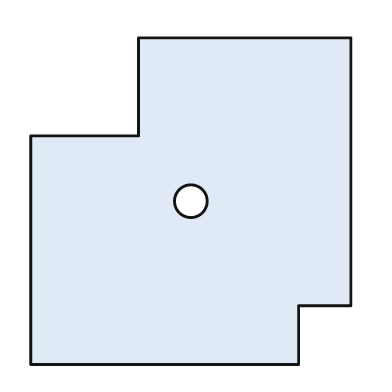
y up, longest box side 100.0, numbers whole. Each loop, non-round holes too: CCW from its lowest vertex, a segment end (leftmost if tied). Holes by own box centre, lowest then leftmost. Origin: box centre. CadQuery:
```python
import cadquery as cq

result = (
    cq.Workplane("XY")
    .moveTo(-49.0, -50.0)
    .lineTo(33.0, -50.0)
    .lineTo(33.0, -32.0)
    .lineTo(49.0, -32.0)
    .lineTo(49.0, 50.0)
    .lineTo(-16.0, 50.0)
    .lineTo(-16.0, 20.0)
    .lineTo(-49.0, 20.0)
    .close()
    .moveTo(0.0, 0.0)
    .circle(5.0)
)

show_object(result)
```